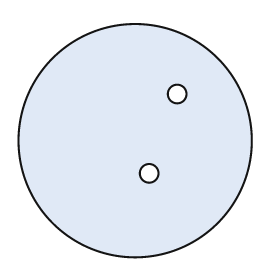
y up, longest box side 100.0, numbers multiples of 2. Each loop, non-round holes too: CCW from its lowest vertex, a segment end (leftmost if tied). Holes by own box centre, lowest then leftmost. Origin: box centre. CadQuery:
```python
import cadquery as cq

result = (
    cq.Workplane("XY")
    .moveTo(0.0, 0.0)
    .circle(50.0)
    .moveTo(6.0, -14.0)
    .circle(4.0)
    .moveTo(18.0, 20.0)
    .circle(4.0)
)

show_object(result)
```